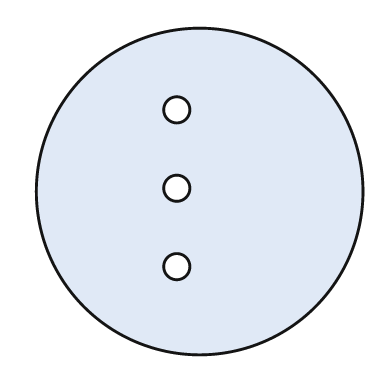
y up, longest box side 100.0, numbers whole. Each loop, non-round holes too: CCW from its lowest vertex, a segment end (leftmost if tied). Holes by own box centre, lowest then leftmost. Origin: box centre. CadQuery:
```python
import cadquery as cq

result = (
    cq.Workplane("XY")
    .moveTo(0.0, 0.0)
    .circle(50.0)
    .moveTo(-7.0, -23.0)
    .circle(4.0)
    .moveTo(-7.0, 1.0)
    .circle(4.0)
    .moveTo(-7.0, 25.0)
    .circle(4.0)
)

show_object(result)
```